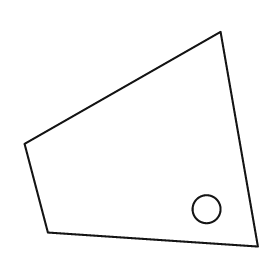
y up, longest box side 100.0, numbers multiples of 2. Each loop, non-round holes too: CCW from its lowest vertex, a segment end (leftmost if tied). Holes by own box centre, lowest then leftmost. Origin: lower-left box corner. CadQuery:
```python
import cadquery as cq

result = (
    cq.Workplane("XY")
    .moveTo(100.0, 0.0)
    .lineTo(84.0, 92.0)
    .lineTo(0.0, 44.0)
    .lineTo(10.0, 6.0)
    .close()
    .moveTo(78.0, 16.0)
    .circle(6.0)
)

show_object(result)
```